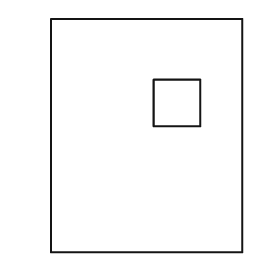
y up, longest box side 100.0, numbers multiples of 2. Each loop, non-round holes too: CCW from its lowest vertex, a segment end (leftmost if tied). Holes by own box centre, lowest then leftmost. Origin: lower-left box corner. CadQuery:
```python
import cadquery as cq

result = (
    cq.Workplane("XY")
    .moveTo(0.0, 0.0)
    .lineTo(82.0, 0.0)
    .lineTo(82.0, 100.0)
    .lineTo(0.0, 100.0)
    .close()
    .moveTo(44.0, 54.0)
    .lineTo(64.0, 54.0)
    .lineTo(64.0, 74.0)
    .lineTo(44.0, 74.0)
    .close()
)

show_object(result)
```